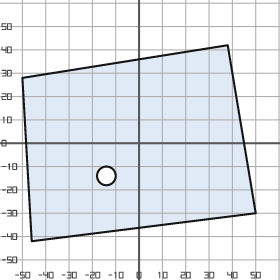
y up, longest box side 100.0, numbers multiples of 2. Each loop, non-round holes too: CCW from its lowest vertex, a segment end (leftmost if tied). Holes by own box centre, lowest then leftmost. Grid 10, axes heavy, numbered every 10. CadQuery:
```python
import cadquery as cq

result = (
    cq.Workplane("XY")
    .moveTo(-46.0, -42.0)
    .lineTo(50.0, -30.0)
    .lineTo(38.0, 42.0)
    .lineTo(-50.0, 28.0)
    .close()
    .moveTo(-14.0, -14.0)
    .circle(4.0)
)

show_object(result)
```